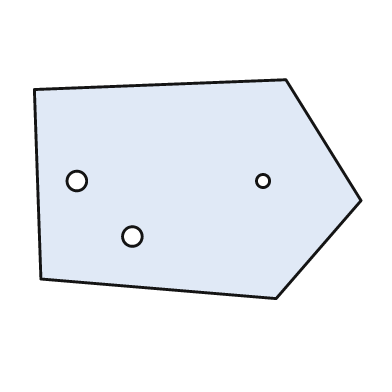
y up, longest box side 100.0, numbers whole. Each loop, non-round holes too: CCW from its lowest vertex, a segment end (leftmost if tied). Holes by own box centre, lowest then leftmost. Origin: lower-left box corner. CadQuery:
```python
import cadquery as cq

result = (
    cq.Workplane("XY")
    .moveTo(74.0, 0.0)
    .lineTo(100.0, 30.0)
    .lineTo(77.0, 67.0)
    .lineTo(0.0, 64.0)
    .lineTo(2.0, 6.0)
    .close()
    .moveTo(30.0, 19.0)
    .circle(3.0)
    .moveTo(13.0, 36.0)
    .circle(3.0)
    .moveTo(70.0, 36.0)
    .circle(2.0)
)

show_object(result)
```